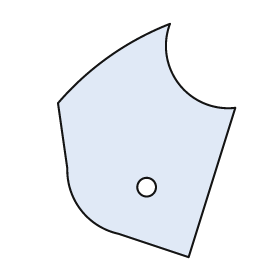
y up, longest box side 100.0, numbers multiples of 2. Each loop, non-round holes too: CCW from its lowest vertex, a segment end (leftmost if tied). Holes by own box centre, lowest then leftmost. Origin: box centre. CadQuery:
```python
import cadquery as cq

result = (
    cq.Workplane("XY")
    .moveTo(18.0, -50.0)
    .lineTo(38.0, 14.0)
    .threePointArc((14.0, 24.0), (10.0, 50.0))
    .threePointArc((-16.0, 36.0), (-38.0, 16.0))
    .lineTo(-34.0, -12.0)
    .threePointArc((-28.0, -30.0), (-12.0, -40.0))
    .close()
    .moveTo(0.0, -20.0)
    .circle(4.0)
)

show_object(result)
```